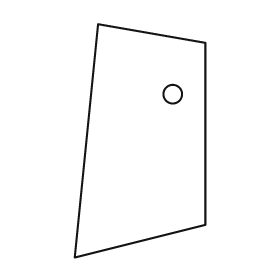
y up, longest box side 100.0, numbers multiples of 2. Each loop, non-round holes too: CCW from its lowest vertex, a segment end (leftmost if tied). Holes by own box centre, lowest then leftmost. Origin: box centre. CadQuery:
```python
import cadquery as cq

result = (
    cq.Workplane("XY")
    .moveTo(-28.0, -50.0)
    .lineTo(28.0, -36.0)
    .lineTo(28.0, 42.0)
    .lineTo(-18.0, 50.0)
    .close()
    .moveTo(14.0, 20.0)
    .circle(4.0)
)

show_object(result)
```